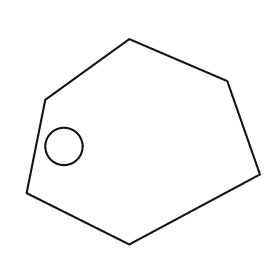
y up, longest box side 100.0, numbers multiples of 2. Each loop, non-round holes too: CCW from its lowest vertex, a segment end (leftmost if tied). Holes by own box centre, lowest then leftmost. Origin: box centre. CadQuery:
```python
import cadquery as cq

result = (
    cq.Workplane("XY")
    .moveTo(-6.0, -44.0)
    .lineTo(50.0, -14.0)
    .lineTo(36.0, 26.0)
    .lineTo(-6.0, 44.0)
    .lineTo(-42.0, 18.0)
    .lineTo(-50.0, -22.0)
    .close()
    .moveTo(-34.0, -2.0)
    .circle(8.0)
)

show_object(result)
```